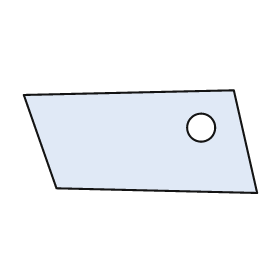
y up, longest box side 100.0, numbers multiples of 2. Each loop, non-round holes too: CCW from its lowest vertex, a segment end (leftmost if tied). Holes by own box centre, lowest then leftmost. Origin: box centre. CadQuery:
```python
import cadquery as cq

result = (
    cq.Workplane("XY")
    .moveTo(50.0, -22.0)
    .lineTo(40.0, 22.0)
    .lineTo(-50.0, 20.0)
    .lineTo(-36.0, -20.0)
    .close()
    .moveTo(26.0, 6.0)
    .circle(6.0)
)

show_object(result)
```